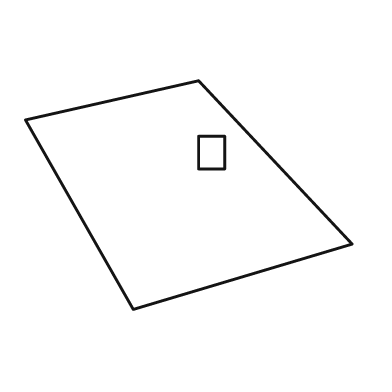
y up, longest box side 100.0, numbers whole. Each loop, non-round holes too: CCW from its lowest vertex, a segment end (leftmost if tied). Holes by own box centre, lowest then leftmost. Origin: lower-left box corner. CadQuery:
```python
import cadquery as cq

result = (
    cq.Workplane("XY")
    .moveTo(33.0, 0.0)
    .lineTo(100.0, 20.0)
    .lineTo(53.0, 70.0)
    .lineTo(0.0, 58.0)
    .close()
    .moveTo(53.0, 43.0)
    .lineTo(61.0, 43.0)
    .lineTo(61.0, 53.0)
    .lineTo(53.0, 53.0)
    .close()
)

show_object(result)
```